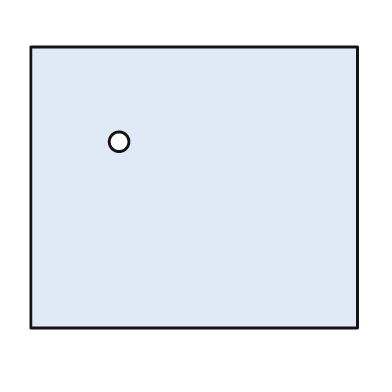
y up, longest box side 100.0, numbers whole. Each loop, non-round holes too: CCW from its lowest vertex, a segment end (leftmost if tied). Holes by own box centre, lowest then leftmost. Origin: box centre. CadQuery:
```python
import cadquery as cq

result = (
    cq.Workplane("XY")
    .moveTo(-50.0, -43.0)
    .lineTo(50.0, -43.0)
    .lineTo(50.0, 43.0)
    .lineTo(-50.0, 43.0)
    .close()
    .moveTo(-23.0, 14.0)
    .circle(3.0)
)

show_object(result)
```